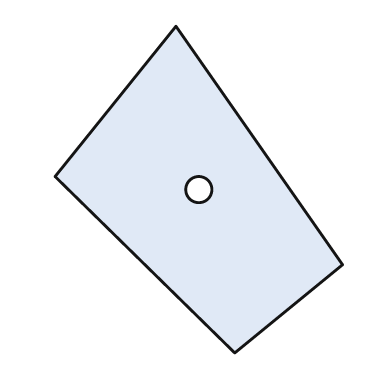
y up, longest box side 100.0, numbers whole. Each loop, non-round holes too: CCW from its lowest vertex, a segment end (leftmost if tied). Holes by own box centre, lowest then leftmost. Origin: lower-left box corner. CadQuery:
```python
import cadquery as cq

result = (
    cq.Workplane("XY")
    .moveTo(55.0, 0.0)
    .lineTo(88.0, 27.0)
    .lineTo(37.0, 100.0)
    .lineTo(0.0, 54.0)
    .close()
    .moveTo(44.0, 50.0)
    .circle(4.0)
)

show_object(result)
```